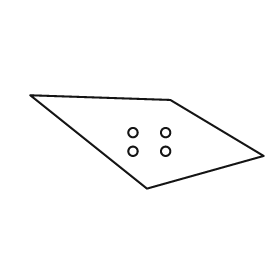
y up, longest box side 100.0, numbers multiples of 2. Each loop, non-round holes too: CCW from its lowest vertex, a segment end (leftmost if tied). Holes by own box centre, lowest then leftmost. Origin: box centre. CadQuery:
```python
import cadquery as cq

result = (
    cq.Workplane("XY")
    .moveTo(0.0, -20.0)
    .lineTo(50.0, -6.0)
    .lineTo(10.0, 18.0)
    .lineTo(-50.0, 20.0)
    .close()
    .moveTo(-6.0, -4.0)
    .circle(2.0)
    .moveTo(8.0, -4.0)
    .circle(2.0)
    .moveTo(-6.0, 4.0)
    .circle(2.0)
    .moveTo(8.0, 4.0)
    .circle(2.0)
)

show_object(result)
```